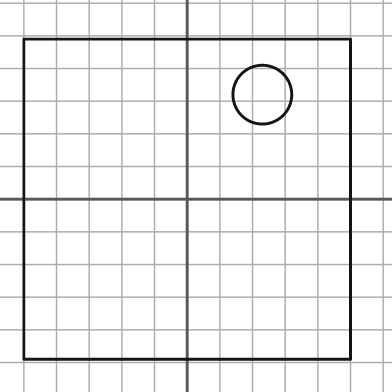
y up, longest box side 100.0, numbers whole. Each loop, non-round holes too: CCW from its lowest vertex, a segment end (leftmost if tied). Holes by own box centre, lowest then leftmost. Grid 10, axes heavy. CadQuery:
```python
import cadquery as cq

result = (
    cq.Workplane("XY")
    .moveTo(-50.0, -49.0)
    .lineTo(50.0, -49.0)
    .lineTo(50.0, 49.0)
    .lineTo(-50.0, 49.0)
    .close()
    .moveTo(23.0, 32.0)
    .circle(9.0)
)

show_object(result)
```